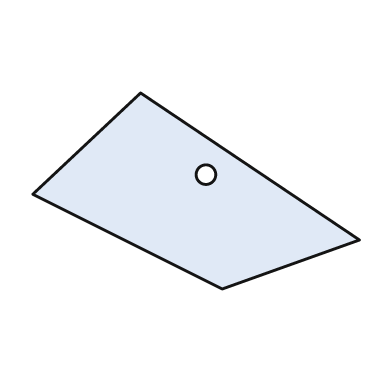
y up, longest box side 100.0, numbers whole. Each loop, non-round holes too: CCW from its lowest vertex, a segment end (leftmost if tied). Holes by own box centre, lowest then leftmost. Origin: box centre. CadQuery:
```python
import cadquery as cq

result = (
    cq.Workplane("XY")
    .moveTo(8.0, -30.0)
    .lineTo(50.0, -15.0)
    .lineTo(-17.0, 30.0)
    .lineTo(-50.0, -1.0)
    .close()
    .moveTo(3.0, 5.0)
    .circle(3.0)
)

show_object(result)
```